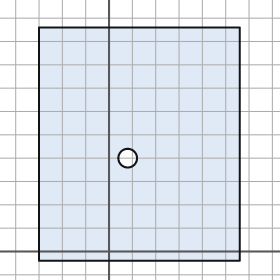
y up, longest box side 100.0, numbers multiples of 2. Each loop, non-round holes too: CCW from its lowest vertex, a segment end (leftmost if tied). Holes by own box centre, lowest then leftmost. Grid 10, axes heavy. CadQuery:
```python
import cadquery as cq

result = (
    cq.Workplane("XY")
    .moveTo(-30.0, -4.0)
    .lineTo(56.0, -4.0)
    .lineTo(56.0, 96.0)
    .lineTo(-30.0, 96.0)
    .close()
    .moveTo(8.0, 40.0)
    .circle(4.0)
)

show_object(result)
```